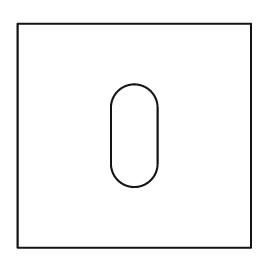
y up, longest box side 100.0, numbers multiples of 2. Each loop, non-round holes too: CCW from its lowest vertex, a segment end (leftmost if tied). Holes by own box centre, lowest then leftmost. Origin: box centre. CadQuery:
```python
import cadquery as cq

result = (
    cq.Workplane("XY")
    .moveTo(-50.0, -48.0)
    .lineTo(50.0, -48.0)
    .lineTo(50.0, 48.0)
    .lineTo(-50.0, 48.0)
    .close()
    .moveTo(-10.0, -12.0)
    .threePointArc((0.0, -22.0), (10.0, -12.0))
    .lineTo(10.0, 12.0)
    .threePointArc((0.0, 22.0), (-10.0, 12.0))
    .close()
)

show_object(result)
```